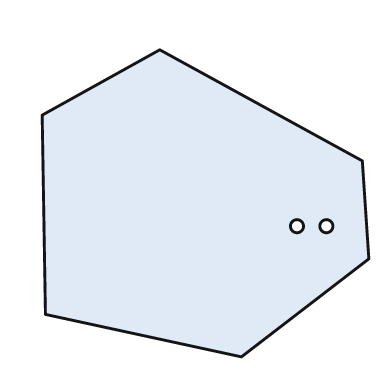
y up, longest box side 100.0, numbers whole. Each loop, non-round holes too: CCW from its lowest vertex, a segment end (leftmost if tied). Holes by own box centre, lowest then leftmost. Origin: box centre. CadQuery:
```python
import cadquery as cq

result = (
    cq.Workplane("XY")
    .moveTo(11.0, -47.0)
    .lineTo(50.0, -17.0)
    .lineTo(48.0, 13.0)
    .lineTo(-14.0, 47.0)
    .lineTo(-50.0, 27.0)
    .lineTo(-49.0, -34.0)
    .close()
    .moveTo(28.0, -7.0)
    .circle(2.0)
    .moveTo(37.0, -7.0)
    .circle(2.0)
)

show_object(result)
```